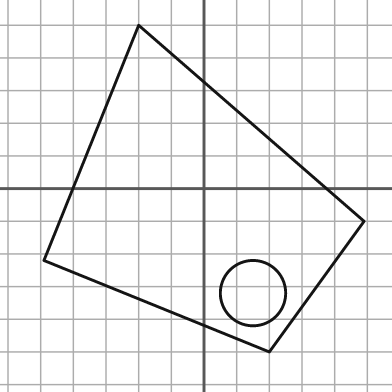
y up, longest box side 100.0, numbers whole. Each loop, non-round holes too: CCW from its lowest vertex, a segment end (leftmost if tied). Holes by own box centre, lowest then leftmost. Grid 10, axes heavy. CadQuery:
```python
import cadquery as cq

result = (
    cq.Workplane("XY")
    .moveTo(20.0, -50.0)
    .lineTo(49.0, -10.0)
    .lineTo(-20.0, 50.0)
    .lineTo(-49.0, -22.0)
    .close()
    .moveTo(15.0, -32.0)
    .circle(10.0)
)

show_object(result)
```